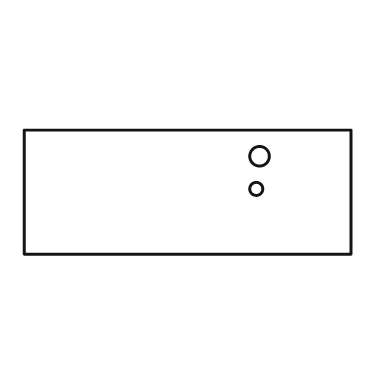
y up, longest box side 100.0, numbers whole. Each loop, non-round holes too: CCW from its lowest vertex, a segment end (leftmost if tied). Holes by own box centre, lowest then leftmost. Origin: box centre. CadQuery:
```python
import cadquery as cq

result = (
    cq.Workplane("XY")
    .moveTo(-50.0, -19.0)
    .lineTo(50.0, -19.0)
    .lineTo(50.0, 19.0)
    .lineTo(-50.0, 19.0)
    .close()
    .moveTo(21.0, 1.0)
    .circle(2.0)
    .moveTo(22.0, 11.0)
    .circle(3.0)
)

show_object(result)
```